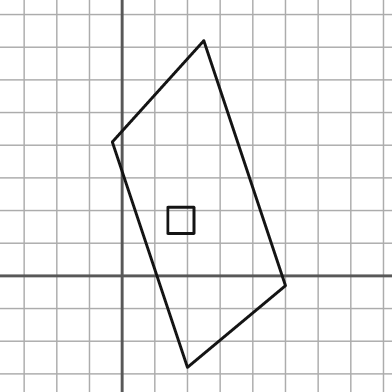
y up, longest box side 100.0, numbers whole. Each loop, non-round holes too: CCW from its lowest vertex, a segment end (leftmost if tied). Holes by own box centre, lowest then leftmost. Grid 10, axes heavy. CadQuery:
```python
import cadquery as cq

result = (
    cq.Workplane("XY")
    .moveTo(20.0, -28.0)
    .lineTo(50.0, -3.0)
    .lineTo(25.0, 72.0)
    .lineTo(-3.0, 41.0)
    .close()
    .moveTo(14.0, 13.0)
    .lineTo(22.0, 13.0)
    .lineTo(22.0, 21.0)
    .lineTo(14.0, 21.0)
    .close()
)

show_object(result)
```